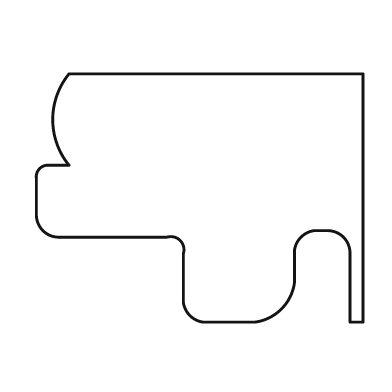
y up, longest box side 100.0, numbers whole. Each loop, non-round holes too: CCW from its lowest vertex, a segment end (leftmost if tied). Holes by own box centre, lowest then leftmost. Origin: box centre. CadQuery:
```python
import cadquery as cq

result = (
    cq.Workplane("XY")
    .moveTo(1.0, -38.0)
    .lineTo(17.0, -38.0)
    .threePointArc((25.0, -34.0), (29.0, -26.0))
    .lineTo(29.0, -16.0)
    .threePointArc((31.0, -12.0), (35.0, -10.0))
    .lineTo(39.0, -10.0)
    .threePointArc((44.0, -12.0), (46.0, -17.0))
    .lineTo(46.0, -38.0)
    .lineTo(50.0, -38.0)
    .lineTo(50.0, 38.0)
    .lineTo(-40.0, 38.0)
    .threePointArc((-45.0, 24.0), (-40.0, 10.0))
    .lineTo(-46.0, 10.0)
    .threePointArc((-49.0, 9.0), (-50.0, 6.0))
    .lineTo(-50.0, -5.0)
    .threePointArc((-48.0, -10.0), (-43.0, -12.0))
    .lineTo(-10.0, -12.0)
    .threePointArc((-6.0, -13.0), (-5.0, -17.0))
    .lineTo(-5.0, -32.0)
    .threePointArc((-3.0, -36.0), (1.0, -38.0))
    .close()
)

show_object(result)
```